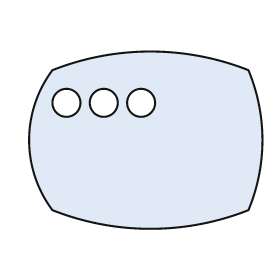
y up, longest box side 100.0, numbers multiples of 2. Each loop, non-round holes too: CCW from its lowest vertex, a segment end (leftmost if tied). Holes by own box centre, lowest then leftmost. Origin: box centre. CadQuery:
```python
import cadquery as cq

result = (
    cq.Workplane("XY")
    .moveTo(-40.0, -30.0)
    .threePointArc((2.0, -38.0), (44.0, -30.0))
    .threePointArc((50.0, 0.0), (44.0, 30.0))
    .threePointArc((2.0, 38.0), (-40.0, 30.0))
    .threePointArc((-50.0, 0.0), (-40.0, -30.0))
    .close()
    .moveTo(-34.0, 16.0)
    .circle(6.0)
    .moveTo(-18.0, 16.0)
    .circle(6.0)
    .moveTo(-2.0, 16.0)
    .circle(6.0)
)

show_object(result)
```